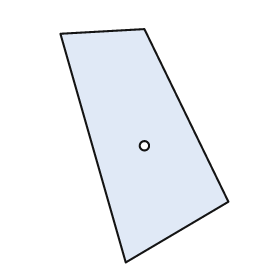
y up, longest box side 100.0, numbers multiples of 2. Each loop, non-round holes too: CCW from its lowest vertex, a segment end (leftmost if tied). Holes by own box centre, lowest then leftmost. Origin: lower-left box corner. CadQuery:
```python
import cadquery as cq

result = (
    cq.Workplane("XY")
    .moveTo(28.0, 0.0)
    .lineTo(72.0, 26.0)
    .lineTo(36.0, 100.0)
    .lineTo(0.0, 98.0)
    .close()
    .moveTo(36.0, 50.0)
    .circle(2.0)
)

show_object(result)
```